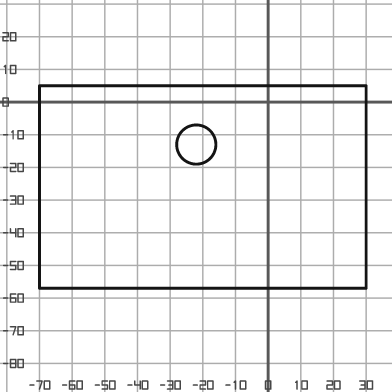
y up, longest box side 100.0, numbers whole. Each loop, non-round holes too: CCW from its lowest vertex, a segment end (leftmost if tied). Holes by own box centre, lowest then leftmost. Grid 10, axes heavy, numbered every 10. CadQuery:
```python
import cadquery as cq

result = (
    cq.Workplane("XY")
    .moveTo(-70.0, -57.0)
    .lineTo(30.0, -57.0)
    .lineTo(30.0, 5.0)
    .lineTo(-70.0, 5.0)
    .close()
    .moveTo(-22.0, -13.0)
    .circle(6.0)
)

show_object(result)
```